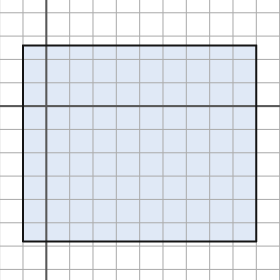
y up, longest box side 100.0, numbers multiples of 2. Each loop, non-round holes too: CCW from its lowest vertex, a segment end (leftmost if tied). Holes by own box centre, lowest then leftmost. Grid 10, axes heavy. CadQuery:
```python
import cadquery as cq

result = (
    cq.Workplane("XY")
    .moveTo(-10.0, -58.0)
    .lineTo(90.0, -58.0)
    .lineTo(90.0, 26.0)
    .lineTo(-10.0, 26.0)
    .close()
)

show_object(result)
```